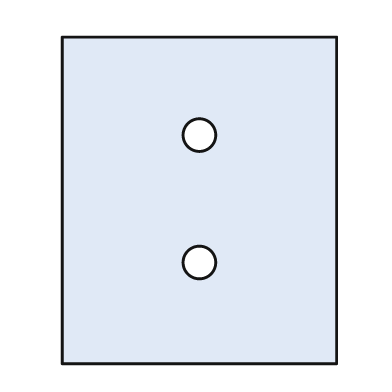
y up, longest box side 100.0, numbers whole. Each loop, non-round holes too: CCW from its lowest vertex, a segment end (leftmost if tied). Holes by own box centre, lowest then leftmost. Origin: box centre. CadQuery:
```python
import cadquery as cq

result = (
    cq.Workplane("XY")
    .moveTo(-42.0, -50.0)
    .lineTo(42.0, -50.0)
    .lineTo(42.0, 50.0)
    .lineTo(-42.0, 50.0)
    .close()
    .moveTo(0.0, -19.0)
    .circle(5.0)
    .moveTo(0.0, 20.0)
    .circle(5.0)
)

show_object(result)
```